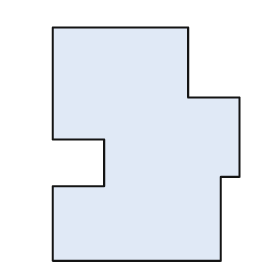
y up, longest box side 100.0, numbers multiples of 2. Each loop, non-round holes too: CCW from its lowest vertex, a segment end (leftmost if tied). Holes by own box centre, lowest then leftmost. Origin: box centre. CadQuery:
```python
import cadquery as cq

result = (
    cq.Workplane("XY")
    .moveTo(-40.0, -50.0)
    .lineTo(32.0, -50.0)
    .lineTo(32.0, -14.0)
    .lineTo(40.0, -14.0)
    .lineTo(40.0, 20.0)
    .lineTo(18.0, 20.0)
    .lineTo(18.0, 50.0)
    .lineTo(-40.0, 50.0)
    .lineTo(-40.0, 2.0)
    .lineTo(-18.0, 2.0)
    .lineTo(-18.0, -18.0)
    .lineTo(-40.0, -18.0)
    .close()
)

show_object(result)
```